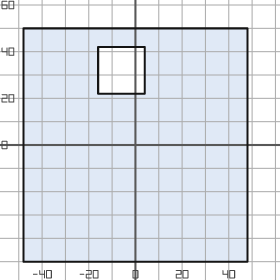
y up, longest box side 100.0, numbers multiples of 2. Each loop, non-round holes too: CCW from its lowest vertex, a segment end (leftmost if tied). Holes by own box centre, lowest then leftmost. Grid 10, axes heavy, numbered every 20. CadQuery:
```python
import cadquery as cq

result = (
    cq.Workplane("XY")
    .moveTo(-48.0, -50.0)
    .lineTo(48.0, -50.0)
    .lineTo(48.0, 50.0)
    .lineTo(-48.0, 50.0)
    .close()
    .moveTo(-16.0, 22.0)
    .lineTo(4.0, 22.0)
    .lineTo(4.0, 42.0)
    .lineTo(-16.0, 42.0)
    .close()
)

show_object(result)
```